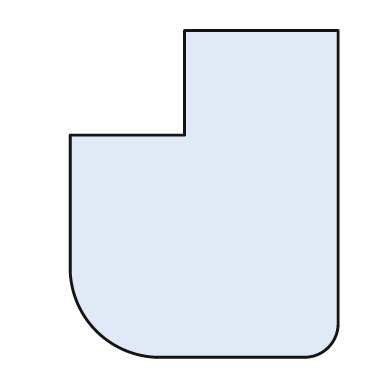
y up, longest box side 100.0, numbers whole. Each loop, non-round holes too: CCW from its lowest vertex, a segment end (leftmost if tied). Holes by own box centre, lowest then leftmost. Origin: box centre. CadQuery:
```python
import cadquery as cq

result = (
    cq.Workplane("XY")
    .moveTo(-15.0, -50.0)
    .lineTo(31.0, -50.0)
    .threePointArc((38.0, -47.0), (41.0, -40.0))
    .lineTo(41.0, 50.0)
    .lineTo(-6.0, 50.0)
    .lineTo(-6.0, 18.0)
    .lineTo(-41.0, 18.0)
    .lineTo(-41.0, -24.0)
    .threePointArc((-33.0, -42.0), (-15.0, -50.0))
    .close()
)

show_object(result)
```